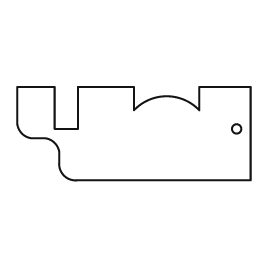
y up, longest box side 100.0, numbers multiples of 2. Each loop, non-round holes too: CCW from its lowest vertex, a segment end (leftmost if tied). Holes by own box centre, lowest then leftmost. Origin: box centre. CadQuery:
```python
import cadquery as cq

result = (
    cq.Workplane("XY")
    .moveTo(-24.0, -20.0)
    .lineTo(50.0, -20.0)
    .lineTo(50.0, 20.0)
    .lineTo(28.0, 20.0)
    .lineTo(28.0, 10.0)
    .threePointArc((14.0, 16.0), (0.0, 10.0))
    .lineTo(0.0, 20.0)
    .lineTo(-24.0, 20.0)
    .lineTo(-24.0, 2.0)
    .lineTo(-34.0, 2.0)
    .lineTo(-34.0, 20.0)
    .lineTo(-50.0, 20.0)
    .lineTo(-50.0, 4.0)
    .threePointArc((-48.0, 0.0), (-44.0, -2.0))
    .lineTo(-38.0, -2.0)
    .threePointArc((-34.0, -4.0), (-32.0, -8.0))
    .lineTo(-32.0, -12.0)
    .threePointArc((-30.0, -18.0), (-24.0, -20.0))
    .close()
    .moveTo(44.0, 2.0)
    .circle(2.0)
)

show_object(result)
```